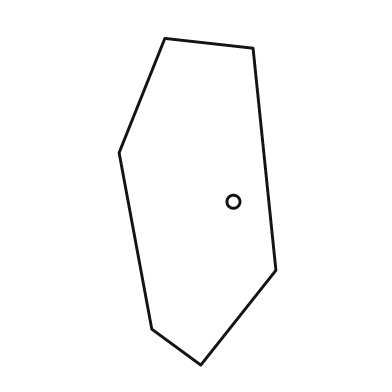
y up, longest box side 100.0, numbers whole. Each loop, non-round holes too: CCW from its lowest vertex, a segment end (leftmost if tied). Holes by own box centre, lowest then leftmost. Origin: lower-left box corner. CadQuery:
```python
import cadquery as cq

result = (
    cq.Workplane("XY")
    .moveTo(25.0, 0.0)
    .lineTo(48.0, 29.0)
    .lineTo(41.0, 97.0)
    .lineTo(14.0, 100.0)
    .lineTo(0.0, 65.0)
    .lineTo(10.0, 11.0)
    .close()
    .moveTo(35.0, 50.0)
    .circle(2.0)
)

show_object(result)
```